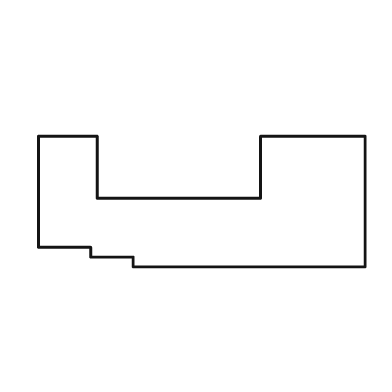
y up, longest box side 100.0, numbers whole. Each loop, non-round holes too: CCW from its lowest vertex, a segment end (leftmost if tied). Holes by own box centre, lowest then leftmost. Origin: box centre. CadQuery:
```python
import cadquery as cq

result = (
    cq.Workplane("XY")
    .moveTo(-21.0, -20.0)
    .lineTo(50.0, -20.0)
    .lineTo(50.0, 20.0)
    .lineTo(18.0, 20.0)
    .lineTo(18.0, 1.0)
    .lineTo(-32.0, 1.0)
    .lineTo(-32.0, 20.0)
    .lineTo(-50.0, 20.0)
    .lineTo(-50.0, -14.0)
    .lineTo(-34.0, -14.0)
    .lineTo(-34.0, -17.0)
    .lineTo(-21.0, -17.0)
    .close()
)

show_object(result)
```